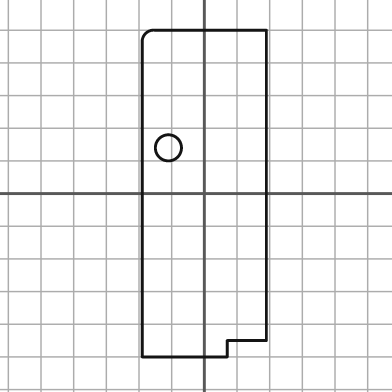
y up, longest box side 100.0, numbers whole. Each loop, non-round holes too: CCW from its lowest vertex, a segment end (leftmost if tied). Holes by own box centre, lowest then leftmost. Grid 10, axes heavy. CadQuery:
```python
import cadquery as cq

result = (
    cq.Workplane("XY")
    .moveTo(-19.0, -50.0)
    .lineTo(7.0, -50.0)
    .lineTo(7.0, -45.0)
    .lineTo(19.0, -45.0)
    .lineTo(19.0, 50.0)
    .lineTo(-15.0, 50.0)
    .threePointArc((-18.0, 49.0), (-19.0, 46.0))
    .close()
    .moveTo(-11.0, 14.0)
    .circle(4.0)
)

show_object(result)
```